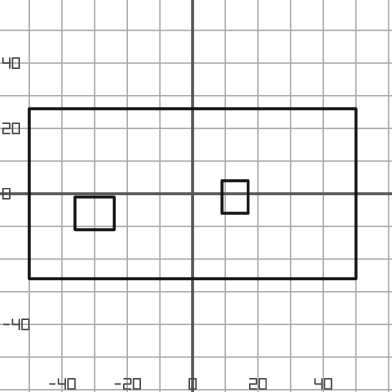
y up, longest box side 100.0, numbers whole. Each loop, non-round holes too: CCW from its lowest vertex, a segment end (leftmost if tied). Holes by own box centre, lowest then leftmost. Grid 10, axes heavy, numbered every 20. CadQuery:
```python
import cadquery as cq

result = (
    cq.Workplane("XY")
    .moveTo(-50.0, -26.0)
    .lineTo(50.0, -26.0)
    .lineTo(50.0, 26.0)
    .lineTo(-50.0, 26.0)
    .close()
    .moveTo(-36.0, -11.0)
    .lineTo(-24.0, -11.0)
    .lineTo(-24.0, -1.0)
    .lineTo(-36.0, -1.0)
    .close()
    .moveTo(9.0, -6.0)
    .lineTo(17.0, -6.0)
    .lineTo(17.0, 4.0)
    .lineTo(9.0, 4.0)
    .close()
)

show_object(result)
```